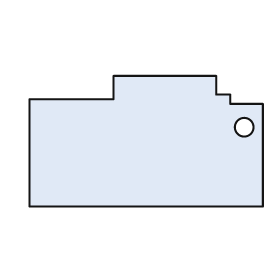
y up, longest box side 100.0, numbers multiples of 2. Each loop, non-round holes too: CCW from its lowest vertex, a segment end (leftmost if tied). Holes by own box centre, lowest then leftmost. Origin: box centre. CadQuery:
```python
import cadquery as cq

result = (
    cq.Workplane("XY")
    .moveTo(-50.0, -28.0)
    .lineTo(50.0, -28.0)
    .lineTo(50.0, 16.0)
    .lineTo(36.0, 16.0)
    .lineTo(36.0, 20.0)
    .lineTo(30.0, 20.0)
    .lineTo(30.0, 28.0)
    .lineTo(-14.0, 28.0)
    .lineTo(-14.0, 18.0)
    .lineTo(-50.0, 18.0)
    .close()
    .moveTo(42.0, 6.0)
    .circle(4.0)
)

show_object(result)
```